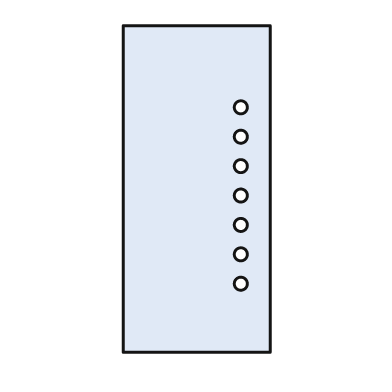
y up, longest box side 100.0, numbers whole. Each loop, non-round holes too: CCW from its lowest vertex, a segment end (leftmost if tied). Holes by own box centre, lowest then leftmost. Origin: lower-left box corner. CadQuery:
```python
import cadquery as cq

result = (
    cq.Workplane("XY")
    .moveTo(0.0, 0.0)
    .lineTo(45.0, 0.0)
    .lineTo(45.0, 100.0)
    .lineTo(0.0, 100.0)
    .close()
    .moveTo(36.0, 21.0)
    .circle(2.0)
    .moveTo(36.0, 30.0)
    .circle(2.0)
    .moveTo(36.0, 39.0)
    .circle(2.0)
    .moveTo(36.0, 48.0)
    .circle(2.0)
    .moveTo(36.0, 57.0)
    .circle(2.0)
    .moveTo(36.0, 66.0)
    .circle(2.0)
    .moveTo(36.0, 75.0)
    .circle(2.0)
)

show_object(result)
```